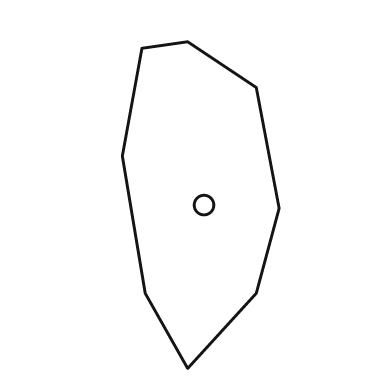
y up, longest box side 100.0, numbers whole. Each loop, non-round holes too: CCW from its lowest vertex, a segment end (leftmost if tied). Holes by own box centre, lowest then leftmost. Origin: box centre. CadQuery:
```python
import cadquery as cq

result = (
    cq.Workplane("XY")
    .moveTo(-4.0, -50.0)
    .lineTo(17.0, -27.0)
    .lineTo(24.0, -1.0)
    .lineTo(17.0, 36.0)
    .lineTo(-4.0, 50.0)
    .lineTo(-18.0, 48.0)
    .lineTo(-24.0, 15.0)
    .lineTo(-17.0, -27.0)
    .close()
    .moveTo(1.0, 0.0)
    .circle(3.0)
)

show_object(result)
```